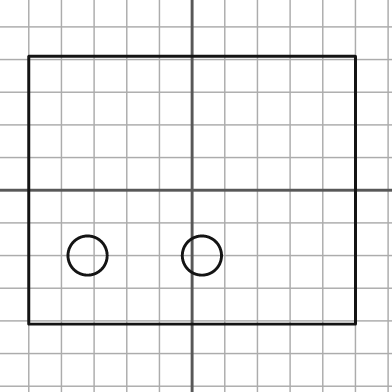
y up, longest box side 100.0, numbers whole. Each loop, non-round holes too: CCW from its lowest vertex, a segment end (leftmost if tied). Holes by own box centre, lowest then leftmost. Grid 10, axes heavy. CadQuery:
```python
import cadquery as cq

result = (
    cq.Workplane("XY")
    .moveTo(-50.0, -41.0)
    .lineTo(50.0, -41.0)
    .lineTo(50.0, 41.0)
    .lineTo(-50.0, 41.0)
    .close()
    .moveTo(-32.0, -20.0)
    .circle(6.0)
    .moveTo(3.0, -20.0)
    .circle(6.0)
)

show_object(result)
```